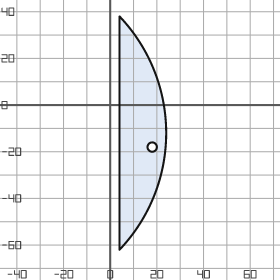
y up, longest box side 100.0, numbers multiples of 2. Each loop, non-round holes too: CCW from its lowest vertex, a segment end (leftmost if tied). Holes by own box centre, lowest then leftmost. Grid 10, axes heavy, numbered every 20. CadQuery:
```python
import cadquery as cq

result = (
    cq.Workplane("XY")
    .moveTo(4.0, -62.0)
    .threePointArc((24.0, -12.0), (4.0, 38.0))
    .close()
    .moveTo(18.0, -18.0)
    .circle(2.0)
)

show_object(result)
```